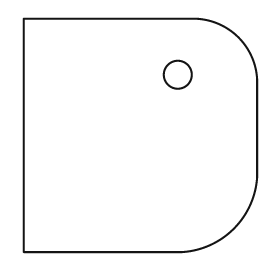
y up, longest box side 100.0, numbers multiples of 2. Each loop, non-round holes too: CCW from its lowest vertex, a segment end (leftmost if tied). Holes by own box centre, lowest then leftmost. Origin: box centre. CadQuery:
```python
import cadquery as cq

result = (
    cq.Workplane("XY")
    .moveTo(-50.0, -50.0)
    .lineTo(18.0, -50.0)
    .threePointArc((40.0, -40.0), (50.0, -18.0))
    .lineTo(50.0, 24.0)
    .threePointArc((42.0, 42.0), (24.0, 50.0))
    .lineTo(-50.0, 50.0)
    .close()
    .moveTo(16.0, 26.0)
    .circle(6.0)
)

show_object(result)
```